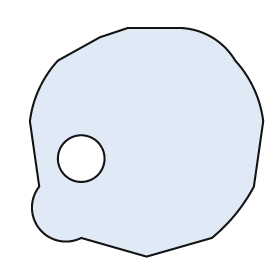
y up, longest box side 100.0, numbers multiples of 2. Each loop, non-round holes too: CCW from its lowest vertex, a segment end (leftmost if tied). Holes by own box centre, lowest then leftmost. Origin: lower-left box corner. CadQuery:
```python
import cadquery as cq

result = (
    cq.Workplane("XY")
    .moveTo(50.0, 0.0)
    .lineTo(78.0, 8.0)
    .threePointArc((88.0, 18.0), (96.0, 30.0))
    .lineTo(100.0, 58.0)
    .threePointArc((96.0, 72.0), (88.0, 84.0))
    .threePointArc((78.0, 94.0), (64.0, 98.0))
    .lineTo(42.0, 98.0)
    .lineTo(30.0, 94.0)
    .lineTo(12.0, 84.0)
    .threePointArc((4.0, 72.0), (0.0, 58.0))
    .lineTo(4.0, 30.0)
    .threePointArc((4.0, 12.0), (22.0, 8.0))
    .close()
    .moveTo(22.0, 42.0)
    .circle(10.0)
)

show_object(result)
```